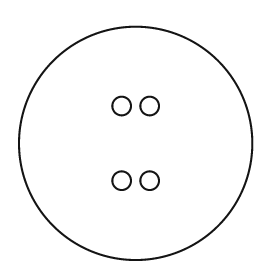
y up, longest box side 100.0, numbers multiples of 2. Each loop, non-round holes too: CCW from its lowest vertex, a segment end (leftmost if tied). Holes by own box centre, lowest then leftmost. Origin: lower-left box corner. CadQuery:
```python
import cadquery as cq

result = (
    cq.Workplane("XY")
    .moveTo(50.0, 50.0)
    .circle(50.0)
    .moveTo(44.0, 34.0)
    .circle(4.0)
    .moveTo(56.0, 34.0)
    .circle(4.0)
    .moveTo(44.0, 66.0)
    .circle(4.0)
    .moveTo(56.0, 66.0)
    .circle(4.0)
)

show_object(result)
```